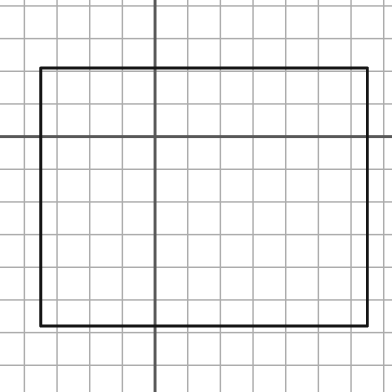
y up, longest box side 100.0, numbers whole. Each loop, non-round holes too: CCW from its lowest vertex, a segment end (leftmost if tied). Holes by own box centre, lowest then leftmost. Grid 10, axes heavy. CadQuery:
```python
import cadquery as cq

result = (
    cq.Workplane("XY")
    .moveTo(-35.0, -58.0)
    .lineTo(65.0, -58.0)
    .lineTo(65.0, 21.0)
    .lineTo(-35.0, 21.0)
    .close()
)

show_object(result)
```